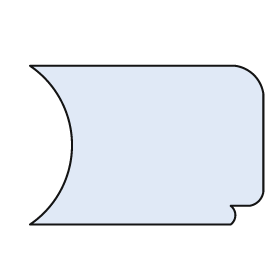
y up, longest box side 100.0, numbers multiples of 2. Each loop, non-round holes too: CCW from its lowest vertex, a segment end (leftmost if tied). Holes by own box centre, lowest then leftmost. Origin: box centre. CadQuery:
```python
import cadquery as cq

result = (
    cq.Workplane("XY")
    .moveTo(-50.0, -34.0)
    .lineTo(36.0, -34.0)
    .threePointArc((38.0, -30.0), (36.0, -26.0))
    .lineTo(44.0, -26.0)
    .threePointArc((48.0, -24.0), (50.0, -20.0))
    .lineTo(50.0, 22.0)
    .threePointArc((46.0, 30.0), (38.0, 34.0))
    .lineTo(-50.0, 34.0)
    .threePointArc((-32.0, 0.0), (-50.0, -34.0))
    .close()
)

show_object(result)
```